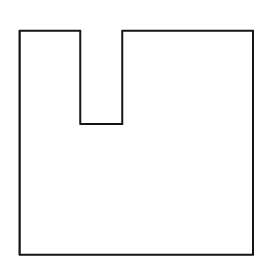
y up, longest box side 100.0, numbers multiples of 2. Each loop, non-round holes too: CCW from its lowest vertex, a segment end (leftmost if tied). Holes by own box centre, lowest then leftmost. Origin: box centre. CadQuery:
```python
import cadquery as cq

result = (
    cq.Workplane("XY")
    .moveTo(-50.0, -48.0)
    .lineTo(50.0, -48.0)
    .lineTo(50.0, 48.0)
    .lineTo(-6.0, 48.0)
    .lineTo(-6.0, 8.0)
    .lineTo(-24.0, 8.0)
    .lineTo(-24.0, 48.0)
    .lineTo(-50.0, 48.0)
    .close()
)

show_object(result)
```